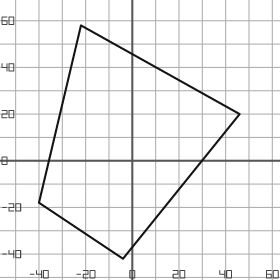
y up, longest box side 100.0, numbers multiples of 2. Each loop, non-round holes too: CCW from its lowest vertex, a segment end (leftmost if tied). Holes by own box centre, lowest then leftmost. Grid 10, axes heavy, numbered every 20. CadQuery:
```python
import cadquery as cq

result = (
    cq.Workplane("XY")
    .moveTo(-4.0, -42.0)
    .lineTo(46.0, 20.0)
    .lineTo(-22.0, 58.0)
    .lineTo(-40.0, -18.0)
    .close()
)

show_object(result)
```